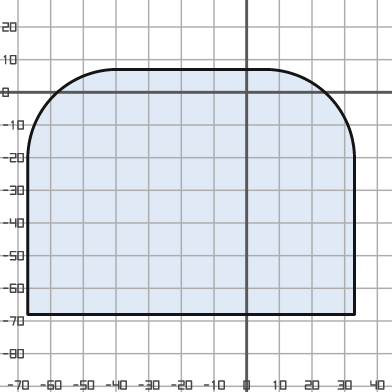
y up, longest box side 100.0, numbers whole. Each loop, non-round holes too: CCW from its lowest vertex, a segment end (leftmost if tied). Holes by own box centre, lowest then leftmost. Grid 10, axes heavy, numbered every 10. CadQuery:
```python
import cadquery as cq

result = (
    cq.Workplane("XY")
    .moveTo(-67.0, -68.0)
    .lineTo(33.0, -68.0)
    .lineTo(33.0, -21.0)
    .threePointArc((25.0, -1.0), (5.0, 7.0))
    .lineTo(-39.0, 7.0)
    .threePointArc((-59.0, -1.0), (-67.0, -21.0))
    .close()
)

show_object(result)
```